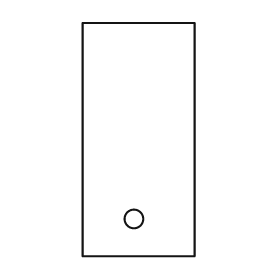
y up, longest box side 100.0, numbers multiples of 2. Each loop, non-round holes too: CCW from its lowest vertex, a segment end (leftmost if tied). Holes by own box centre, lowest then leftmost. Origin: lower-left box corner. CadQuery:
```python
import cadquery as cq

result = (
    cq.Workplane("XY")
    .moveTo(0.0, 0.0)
    .lineTo(48.0, 0.0)
    .lineTo(48.0, 100.0)
    .lineTo(0.0, 100.0)
    .close()
    .moveTo(22.0, 16.0)
    .circle(4.0)
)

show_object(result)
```